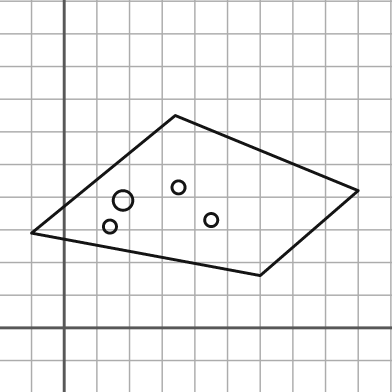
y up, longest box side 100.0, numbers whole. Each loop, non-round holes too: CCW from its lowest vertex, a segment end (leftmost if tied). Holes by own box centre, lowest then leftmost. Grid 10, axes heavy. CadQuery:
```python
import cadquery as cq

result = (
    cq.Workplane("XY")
    .moveTo(60.0, 16.0)
    .lineTo(90.0, 42.0)
    .lineTo(34.0, 65.0)
    .lineTo(-10.0, 29.0)
    .close()
    .moveTo(14.0, 31.0)
    .circle(2.0)
    .moveTo(45.0, 33.0)
    .circle(2.0)
    .moveTo(18.0, 39.0)
    .circle(3.0)
    .moveTo(35.0, 43.0)
    .circle(2.0)
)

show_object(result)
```